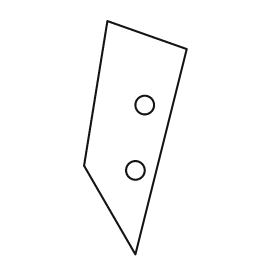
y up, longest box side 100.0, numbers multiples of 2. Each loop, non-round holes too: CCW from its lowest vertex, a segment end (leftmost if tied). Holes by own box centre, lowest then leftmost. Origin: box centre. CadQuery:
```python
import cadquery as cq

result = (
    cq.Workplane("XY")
    .moveTo(0.0, -50.0)
    .lineTo(22.0, 38.0)
    .lineTo(-12.0, 50.0)
    .lineTo(-22.0, -12.0)
    .close()
    .moveTo(0.0, -14.0)
    .circle(4.0)
    .moveTo(4.0, 14.0)
    .circle(4.0)
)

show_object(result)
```